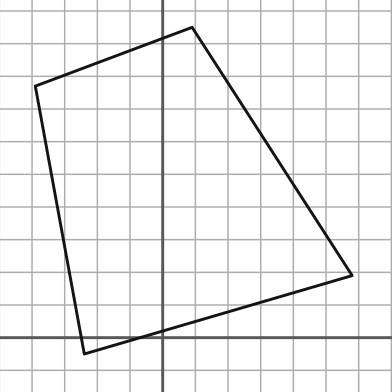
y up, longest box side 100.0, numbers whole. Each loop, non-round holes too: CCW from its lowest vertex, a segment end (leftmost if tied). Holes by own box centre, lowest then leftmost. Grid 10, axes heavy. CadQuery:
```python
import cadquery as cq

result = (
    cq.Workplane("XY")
    .moveTo(-24.0, -5.0)
    .lineTo(58.0, 19.0)
    .lineTo(9.0, 95.0)
    .lineTo(-39.0, 77.0)
    .close()
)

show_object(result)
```